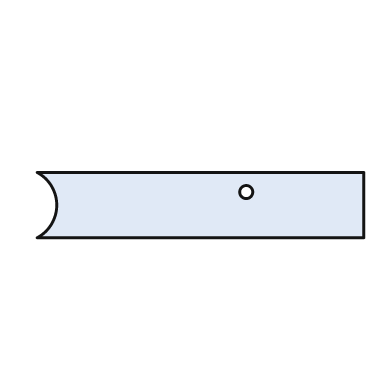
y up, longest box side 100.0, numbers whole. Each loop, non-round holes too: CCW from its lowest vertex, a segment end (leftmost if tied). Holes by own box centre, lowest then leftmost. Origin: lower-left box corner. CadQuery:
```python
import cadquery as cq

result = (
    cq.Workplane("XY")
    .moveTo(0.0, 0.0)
    .lineTo(100.0, 0.0)
    .lineTo(100.0, 20.0)
    .lineTo(0.0, 20.0)
    .threePointArc((6.0, 10.0), (0.0, 0.0))
    .close()
    .moveTo(64.0, 14.0)
    .circle(2.0)
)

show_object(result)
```